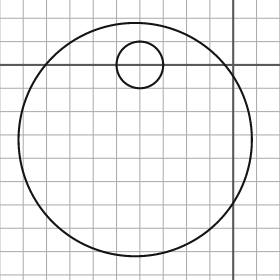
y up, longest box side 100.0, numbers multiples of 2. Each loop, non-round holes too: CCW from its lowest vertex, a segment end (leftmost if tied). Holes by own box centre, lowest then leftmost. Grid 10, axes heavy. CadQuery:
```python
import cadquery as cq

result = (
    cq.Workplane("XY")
    .moveTo(-42.0, -32.0)
    .circle(50.0)
    .moveTo(-40.0, 0.0)
    .circle(10.0)
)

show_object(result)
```